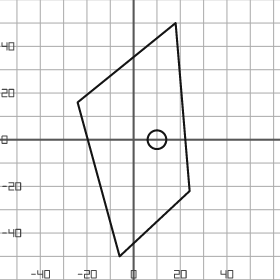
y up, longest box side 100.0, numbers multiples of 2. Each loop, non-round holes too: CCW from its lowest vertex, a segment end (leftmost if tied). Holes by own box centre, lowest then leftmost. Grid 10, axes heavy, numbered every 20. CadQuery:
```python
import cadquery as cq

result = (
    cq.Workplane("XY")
    .moveTo(-6.0, -50.0)
    .lineTo(24.0, -22.0)
    .lineTo(18.0, 50.0)
    .lineTo(-24.0, 16.0)
    .close()
    .moveTo(10.0, 0.0)
    .circle(4.0)
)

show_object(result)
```